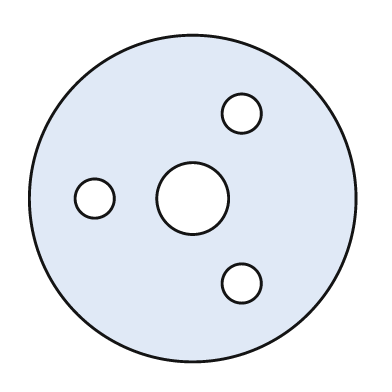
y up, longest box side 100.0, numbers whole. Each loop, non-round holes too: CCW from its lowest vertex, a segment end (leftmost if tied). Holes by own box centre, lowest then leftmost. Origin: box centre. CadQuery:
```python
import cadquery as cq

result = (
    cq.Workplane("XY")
    .moveTo(0.0, 0.0)
    .circle(50.0)
    .moveTo(15.0, -26.0)
    .circle(6.0)
    .moveTo(-30.0, 0.0)
    .circle(6.0)
    .moveTo(0.0, 0.0)
    .circle(11.0)
    .moveTo(15.0, 26.0)
    .circle(6.0)
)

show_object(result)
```